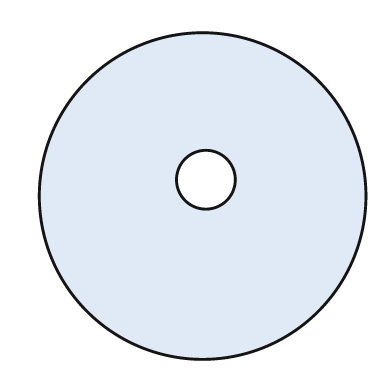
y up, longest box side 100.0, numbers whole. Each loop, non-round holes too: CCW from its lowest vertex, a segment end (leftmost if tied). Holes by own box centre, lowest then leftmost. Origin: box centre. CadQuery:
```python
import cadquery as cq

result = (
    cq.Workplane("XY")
    .moveTo(0.0, 0.0)
    .circle(50.0)
    .moveTo(1.0, 5.0)
    .circle(9.0)
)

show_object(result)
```